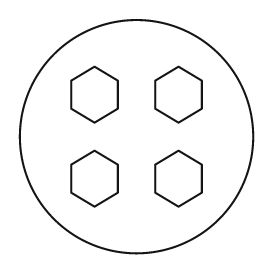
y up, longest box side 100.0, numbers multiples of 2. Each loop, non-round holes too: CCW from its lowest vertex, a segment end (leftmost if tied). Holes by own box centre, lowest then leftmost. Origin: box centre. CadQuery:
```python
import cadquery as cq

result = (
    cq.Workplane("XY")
    .moveTo(0.0, 0.0)
    .circle(50.0)
    .moveTo(-18.0, -30.0)
    .lineTo(-8.0, -24.0)
    .lineTo(-8.0, -12.0)
    .lineTo(-18.0, -6.0)
    .lineTo(-28.0, -12.0)
    .lineTo(-28.0, -24.0)
    .close()
    .moveTo(18.0, -30.0)
    .lineTo(28.0, -24.0)
    .lineTo(28.0, -12.0)
    .lineTo(18.0, -6.0)
    .lineTo(8.0, -12.0)
    .lineTo(8.0, -24.0)
    .close()
    .moveTo(-18.0, 6.0)
    .lineTo(-8.0, 12.0)
    .lineTo(-8.0, 24.0)
    .lineTo(-18.0, 30.0)
    .lineTo(-28.0, 24.0)
    .lineTo(-28.0, 12.0)
    .close()
    .moveTo(18.0, 6.0)
    .lineTo(28.0, 12.0)
    .lineTo(28.0, 24.0)
    .lineTo(18.0, 30.0)
    .lineTo(8.0, 24.0)
    .lineTo(8.0, 12.0)
    .close()
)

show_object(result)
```